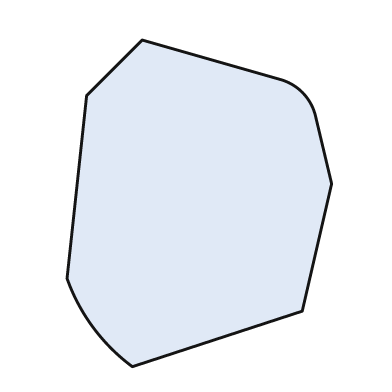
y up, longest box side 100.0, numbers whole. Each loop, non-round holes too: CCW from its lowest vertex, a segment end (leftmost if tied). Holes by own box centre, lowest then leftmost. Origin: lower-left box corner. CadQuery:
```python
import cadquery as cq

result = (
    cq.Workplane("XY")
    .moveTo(20.0, 0.0)
    .lineTo(72.0, 17.0)
    .lineTo(81.0, 56.0)
    .lineTo(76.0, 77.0)
    .threePointArc((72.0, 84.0), (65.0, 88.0))
    .lineTo(23.0, 100.0)
    .lineTo(6.0, 83.0)
    .lineTo(0.0, 27.0)
    .threePointArc((8.0, 12.0), (20.0, 0.0))
    .close()
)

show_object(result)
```